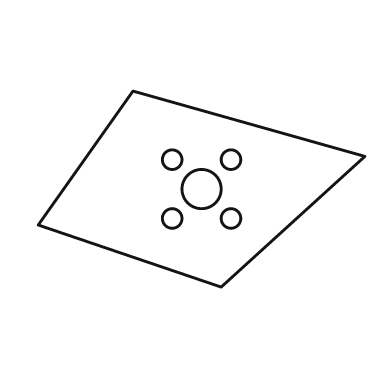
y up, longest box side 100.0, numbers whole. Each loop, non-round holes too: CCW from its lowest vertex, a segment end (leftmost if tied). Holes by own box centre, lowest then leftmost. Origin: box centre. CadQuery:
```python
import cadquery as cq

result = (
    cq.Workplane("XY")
    .moveTo(6.0, -30.0)
    .lineTo(50.0, 10.0)
    .lineTo(-21.0, 30.0)
    .lineTo(-50.0, -11.0)
    .close()
    .moveTo(-9.0, -9.0)
    .circle(3.0)
    .moveTo(9.0, -9.0)
    .circle(3.0)
    .moveTo(0.0, 0.0)
    .circle(6.0)
    .moveTo(-9.0, 9.0)
    .circle(3.0)
    .moveTo(9.0, 9.0)
    .circle(3.0)
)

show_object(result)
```